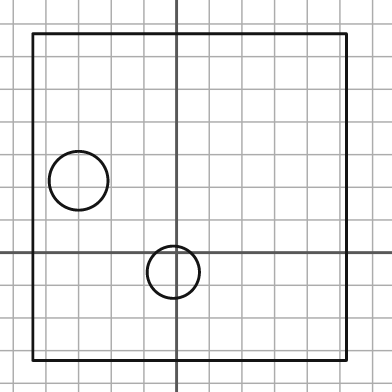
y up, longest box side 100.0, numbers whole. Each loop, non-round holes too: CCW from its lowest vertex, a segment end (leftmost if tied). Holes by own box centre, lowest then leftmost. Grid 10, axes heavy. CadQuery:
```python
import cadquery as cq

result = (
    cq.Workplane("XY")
    .moveTo(-44.0, -33.0)
    .lineTo(52.0, -33.0)
    .lineTo(52.0, 67.0)
    .lineTo(-44.0, 67.0)
    .close()
    .moveTo(-1.0, -6.0)
    .circle(8.0)
    .moveTo(-30.0, 22.0)
    .circle(9.0)
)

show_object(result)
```